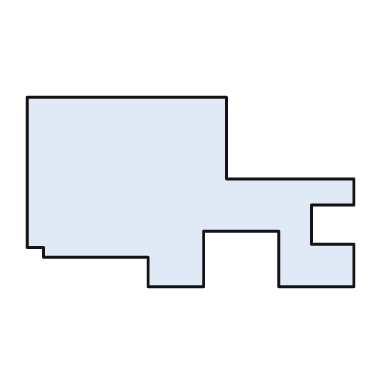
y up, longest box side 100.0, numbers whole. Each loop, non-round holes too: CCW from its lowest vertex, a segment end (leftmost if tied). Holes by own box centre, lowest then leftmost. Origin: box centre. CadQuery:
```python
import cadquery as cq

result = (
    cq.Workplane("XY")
    .moveTo(-13.0, -29.0)
    .lineTo(4.0, -29.0)
    .lineTo(4.0, -12.0)
    .lineTo(27.0, -12.0)
    .lineTo(27.0, -29.0)
    .lineTo(50.0, -29.0)
    .lineTo(50.0, -16.0)
    .lineTo(37.0, -16.0)
    .lineTo(37.0, -4.0)
    .lineTo(50.0, -4.0)
    .lineTo(50.0, 4.0)
    .lineTo(11.0, 4.0)
    .lineTo(11.0, 29.0)
    .lineTo(-50.0, 29.0)
    .lineTo(-50.0, -17.0)
    .lineTo(-45.0, -17.0)
    .lineTo(-45.0, -20.0)
    .lineTo(-13.0, -20.0)
    .close()
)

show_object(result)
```